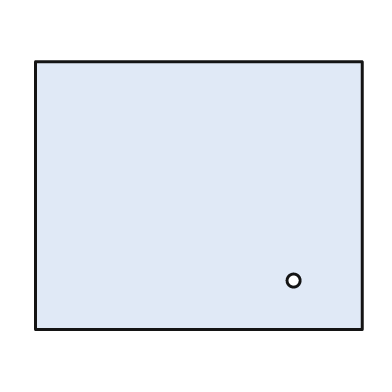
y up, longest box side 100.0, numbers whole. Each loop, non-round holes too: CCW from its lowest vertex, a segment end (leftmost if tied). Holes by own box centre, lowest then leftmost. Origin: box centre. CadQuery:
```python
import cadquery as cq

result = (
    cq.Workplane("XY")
    .moveTo(-50.0, -41.0)
    .lineTo(50.0, -41.0)
    .lineTo(50.0, 41.0)
    .lineTo(-50.0, 41.0)
    .close()
    .moveTo(29.0, -26.0)
    .circle(2.0)
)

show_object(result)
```